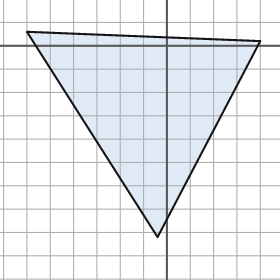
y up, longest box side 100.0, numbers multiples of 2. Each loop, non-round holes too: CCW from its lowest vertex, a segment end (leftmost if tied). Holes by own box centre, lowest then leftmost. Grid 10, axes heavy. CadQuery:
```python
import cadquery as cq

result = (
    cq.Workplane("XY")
    .moveTo(-4.0, -82.0)
    .lineTo(40.0, 2.0)
    .lineTo(-60.0, 6.0)
    .close()
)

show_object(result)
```